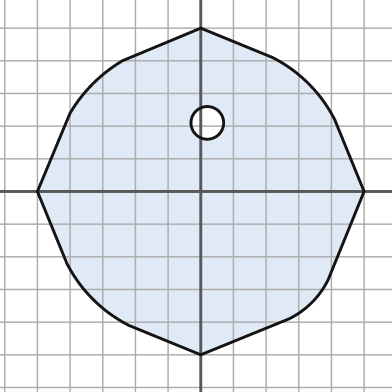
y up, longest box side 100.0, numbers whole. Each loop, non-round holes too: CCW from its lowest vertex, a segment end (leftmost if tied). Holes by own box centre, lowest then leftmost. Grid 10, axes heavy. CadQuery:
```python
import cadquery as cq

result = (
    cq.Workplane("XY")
    .moveTo(0.0, -50.0)
    .lineTo(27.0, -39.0)
    .threePointArc((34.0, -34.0), (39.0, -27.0))
    .lineTo(50.0, 0.0)
    .lineTo(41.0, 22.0)
    .threePointArc((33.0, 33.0), (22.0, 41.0))
    .lineTo(0.0, 50.0)
    .lineTo(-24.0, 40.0)
    .threePointArc((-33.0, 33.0), (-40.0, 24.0))
    .lineTo(-50.0, 0.0)
    .lineTo(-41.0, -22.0)
    .threePointArc((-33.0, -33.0), (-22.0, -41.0))
    .close()
    .moveTo(2.0, 21.0)
    .circle(5.0)
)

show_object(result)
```